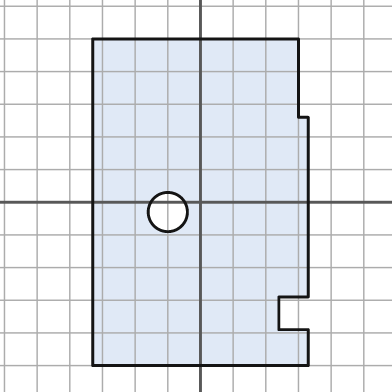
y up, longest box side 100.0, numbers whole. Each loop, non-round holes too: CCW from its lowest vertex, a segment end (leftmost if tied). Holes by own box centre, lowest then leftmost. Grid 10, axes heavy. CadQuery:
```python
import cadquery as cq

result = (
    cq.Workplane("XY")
    .moveTo(-33.0, -50.0)
    .lineTo(33.0, -50.0)
    .lineTo(33.0, -39.0)
    .lineTo(24.0, -39.0)
    .lineTo(24.0, -29.0)
    .lineTo(33.0, -29.0)
    .lineTo(33.0, 26.0)
    .lineTo(30.0, 26.0)
    .lineTo(30.0, 50.0)
    .lineTo(-33.0, 50.0)
    .close()
    .moveTo(-10.0, -3.0)
    .circle(6.0)
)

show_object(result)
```